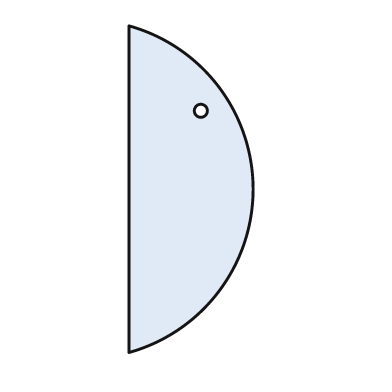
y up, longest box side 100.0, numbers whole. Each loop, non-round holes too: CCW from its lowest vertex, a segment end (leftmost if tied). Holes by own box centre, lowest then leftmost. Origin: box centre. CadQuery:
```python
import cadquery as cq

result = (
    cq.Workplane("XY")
    .moveTo(-19.0, -50.0)
    .threePointArc((19.0, 0.0), (-19.0, 50.0))
    .close()
    .moveTo(3.0, 24.0)
    .circle(2.0)
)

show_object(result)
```